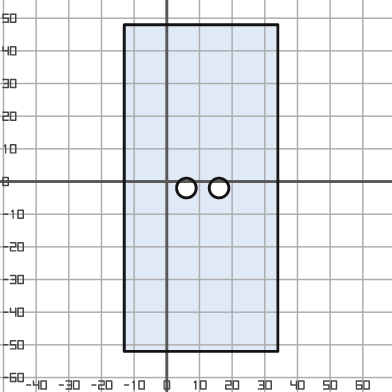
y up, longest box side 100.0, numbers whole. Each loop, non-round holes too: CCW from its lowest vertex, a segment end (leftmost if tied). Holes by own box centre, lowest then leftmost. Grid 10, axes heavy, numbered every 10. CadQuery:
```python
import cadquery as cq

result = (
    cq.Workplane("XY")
    .moveTo(-13.0, -52.0)
    .lineTo(34.0, -52.0)
    .lineTo(34.0, 48.0)
    .lineTo(-13.0, 48.0)
    .close()
    .moveTo(6.0, -2.0)
    .circle(3.0)
    .moveTo(16.0, -2.0)
    .circle(3.0)
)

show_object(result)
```